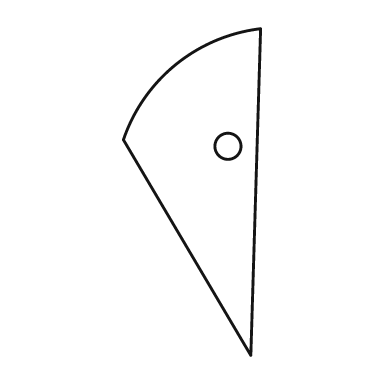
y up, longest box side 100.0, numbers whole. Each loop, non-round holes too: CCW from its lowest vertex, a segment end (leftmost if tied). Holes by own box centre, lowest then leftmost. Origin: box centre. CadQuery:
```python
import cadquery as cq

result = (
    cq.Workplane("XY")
    .moveTo(18.0, -50.0)
    .lineTo(21.0, 50.0)
    .threePointArc((-5.0, 39.0), (-21.0, 16.0))
    .close()
    .moveTo(11.0, 14.0)
    .circle(4.0)
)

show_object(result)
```